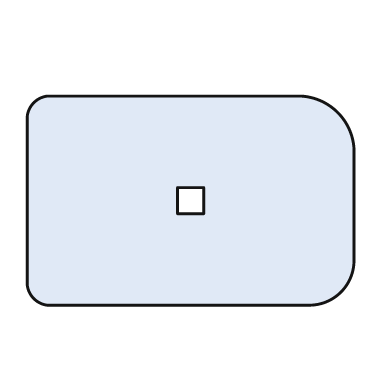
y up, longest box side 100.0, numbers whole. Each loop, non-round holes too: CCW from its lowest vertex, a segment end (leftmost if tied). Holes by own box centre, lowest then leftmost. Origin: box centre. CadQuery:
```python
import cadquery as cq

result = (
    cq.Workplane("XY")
    .moveTo(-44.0, -32.0)
    .lineTo(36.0, -32.0)
    .threePointArc((46.0, -28.0), (50.0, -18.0))
    .lineTo(50.0, 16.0)
    .threePointArc((45.0, 27.0), (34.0, 32.0))
    .lineTo(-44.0, 32.0)
    .threePointArc((-48.0, 30.0), (-50.0, 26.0))
    .lineTo(-50.0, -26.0)
    .threePointArc((-48.0, -30.0), (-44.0, -32.0))
    .close()
    .moveTo(-4.0, -4.0)
    .lineTo(4.0, -4.0)
    .lineTo(4.0, 4.0)
    .lineTo(-4.0, 4.0)
    .close()
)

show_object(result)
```